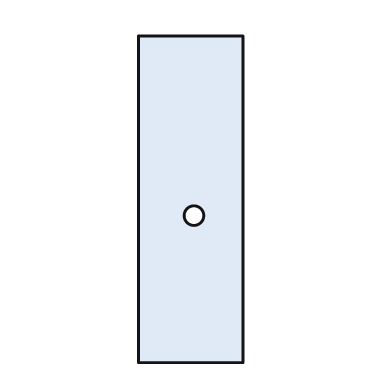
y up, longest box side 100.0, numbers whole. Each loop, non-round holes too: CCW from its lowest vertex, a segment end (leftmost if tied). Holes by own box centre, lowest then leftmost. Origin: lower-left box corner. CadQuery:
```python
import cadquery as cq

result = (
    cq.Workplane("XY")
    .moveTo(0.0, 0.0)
    .lineTo(32.0, 0.0)
    .lineTo(32.0, 100.0)
    .lineTo(0.0, 100.0)
    .close()
    .moveTo(17.0, 45.0)
    .circle(3.0)
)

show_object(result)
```